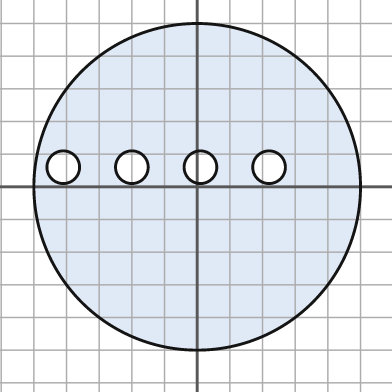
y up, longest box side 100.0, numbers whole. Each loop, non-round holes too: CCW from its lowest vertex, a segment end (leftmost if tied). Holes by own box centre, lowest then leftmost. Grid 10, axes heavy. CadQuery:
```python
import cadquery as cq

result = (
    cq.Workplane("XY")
    .moveTo(0.0, 0.0)
    .circle(50.0)
    .moveTo(-41.0, 6.0)
    .circle(5.0)
    .moveTo(-20.0, 6.0)
    .circle(5.0)
    .moveTo(1.0, 6.0)
    .circle(5.0)
    .moveTo(22.0, 6.0)
    .circle(5.0)
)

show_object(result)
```